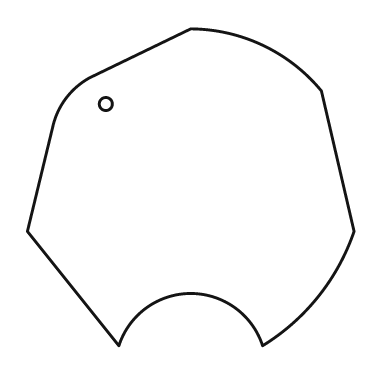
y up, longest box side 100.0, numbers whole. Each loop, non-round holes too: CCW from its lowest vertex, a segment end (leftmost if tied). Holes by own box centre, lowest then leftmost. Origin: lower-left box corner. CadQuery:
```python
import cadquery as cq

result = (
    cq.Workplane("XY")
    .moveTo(28.0, 0.0)
    .threePointArc((50.0, 16.0), (72.0, 0.0))
    .threePointArc((89.0, 15.0), (100.0, 35.0))
    .lineTo(90.0, 78.0)
    .threePointArc((72.0, 92.0), (50.0, 97.0))
    .lineTo(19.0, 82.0)
    .threePointArc((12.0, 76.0), (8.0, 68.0))
    .lineTo(0.0, 35.0)
    .close()
    .moveTo(24.0, 74.0)
    .circle(2.0)
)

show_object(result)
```